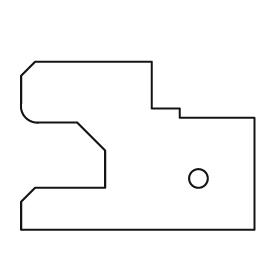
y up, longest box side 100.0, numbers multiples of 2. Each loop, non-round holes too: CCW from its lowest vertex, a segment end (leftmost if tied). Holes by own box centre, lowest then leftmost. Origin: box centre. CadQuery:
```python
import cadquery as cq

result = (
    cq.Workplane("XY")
    .moveTo(-50.0, -36.0)
    .lineTo(50.0, -36.0)
    .lineTo(50.0, 12.0)
    .lineTo(18.0, 12.0)
    .lineTo(18.0, 16.0)
    .lineTo(6.0, 16.0)
    .lineTo(6.0, 36.0)
    .lineTo(-44.0, 36.0)
    .lineTo(-50.0, 30.0)
    .lineTo(-50.0, 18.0)
    .threePointArc((-48.0, 12.0), (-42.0, 10.0))
    .lineTo(-26.0, 10.0)
    .lineTo(-14.0, -2.0)
    .lineTo(-14.0, -18.0)
    .lineTo(-44.0, -18.0)
    .lineTo(-50.0, -24.0)
    .close()
    .moveTo(26.0, -14.0)
    .circle(4.0)
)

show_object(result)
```